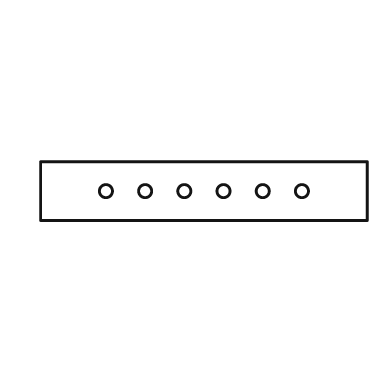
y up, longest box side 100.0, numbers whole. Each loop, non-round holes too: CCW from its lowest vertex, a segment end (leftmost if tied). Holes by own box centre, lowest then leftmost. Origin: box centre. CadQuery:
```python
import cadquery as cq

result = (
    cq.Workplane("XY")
    .moveTo(-50.0, -9.0)
    .lineTo(50.0, -9.0)
    .lineTo(50.0, 9.0)
    .lineTo(-50.0, 9.0)
    .close()
    .moveTo(-30.0, 0.0)
    .circle(2.0)
    .moveTo(-18.0, 0.0)
    .circle(2.0)
    .moveTo(-6.0, 0.0)
    .circle(2.0)
    .moveTo(6.0, 0.0)
    .circle(2.0)
    .moveTo(18.0, 0.0)
    .circle(2.0)
    .moveTo(30.0, 0.0)
    .circle(2.0)
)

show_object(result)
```